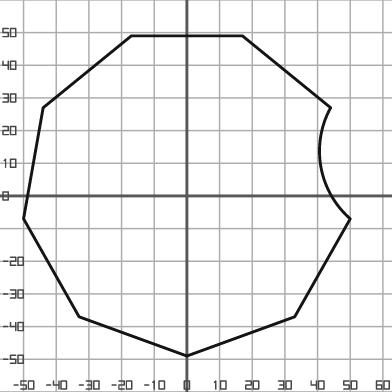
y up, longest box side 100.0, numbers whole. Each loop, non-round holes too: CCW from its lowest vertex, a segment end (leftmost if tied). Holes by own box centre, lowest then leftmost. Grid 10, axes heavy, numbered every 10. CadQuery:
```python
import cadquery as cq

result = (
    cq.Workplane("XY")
    .moveTo(0.0, -49.0)
    .lineTo(33.0, -37.0)
    .lineTo(50.0, -7.0)
    .threePointArc((41.0, 9.0), (44.0, 27.0))
    .lineTo(17.0, 49.0)
    .lineTo(-17.0, 49.0)
    .lineTo(-44.0, 27.0)
    .lineTo(-50.0, -7.0)
    .lineTo(-33.0, -37.0)
    .close()
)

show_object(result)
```